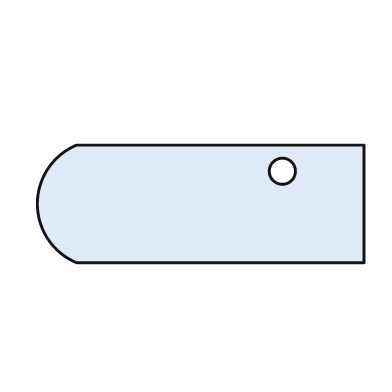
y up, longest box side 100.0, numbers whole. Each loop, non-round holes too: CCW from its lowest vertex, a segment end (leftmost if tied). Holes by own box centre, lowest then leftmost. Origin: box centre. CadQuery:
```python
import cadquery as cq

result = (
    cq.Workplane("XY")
    .moveTo(-38.0, -18.0)
    .lineTo(50.0, -18.0)
    .lineTo(50.0, 18.0)
    .lineTo(-38.0, 18.0)
    .threePointArc((-50.0, 0.0), (-38.0, -18.0))
    .close()
    .moveTo(25.0, 10.0)
    .circle(4.0)
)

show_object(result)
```